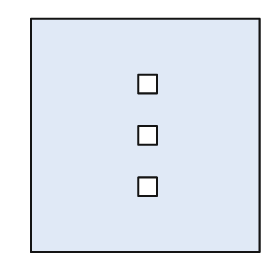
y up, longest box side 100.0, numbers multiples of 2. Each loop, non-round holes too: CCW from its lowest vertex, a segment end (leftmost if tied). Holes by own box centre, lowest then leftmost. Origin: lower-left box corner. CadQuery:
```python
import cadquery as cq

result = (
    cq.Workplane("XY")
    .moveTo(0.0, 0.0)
    .lineTo(98.0, 0.0)
    .lineTo(98.0, 100.0)
    .lineTo(0.0, 100.0)
    .close()
    .moveTo(46.0, 24.0)
    .lineTo(54.0, 24.0)
    .lineTo(54.0, 32.0)
    .lineTo(46.0, 32.0)
    .close()
    .moveTo(46.0, 46.0)
    .lineTo(54.0, 46.0)
    .lineTo(54.0, 54.0)
    .lineTo(46.0, 54.0)
    .close()
    .moveTo(46.0, 68.0)
    .lineTo(54.0, 68.0)
    .lineTo(54.0, 76.0)
    .lineTo(46.0, 76.0)
    .close()
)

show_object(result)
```